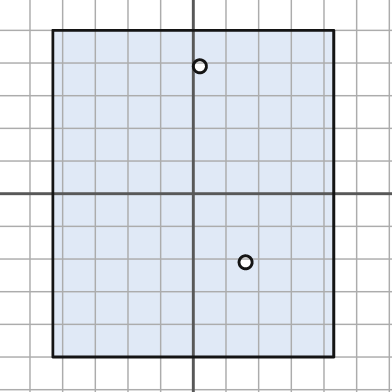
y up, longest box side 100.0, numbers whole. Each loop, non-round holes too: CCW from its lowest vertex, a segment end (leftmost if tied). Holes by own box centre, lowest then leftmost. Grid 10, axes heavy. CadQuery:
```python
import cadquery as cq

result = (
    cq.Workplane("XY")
    .moveTo(-43.0, -50.0)
    .lineTo(43.0, -50.0)
    .lineTo(43.0, 50.0)
    .lineTo(-43.0, 50.0)
    .close()
    .moveTo(16.0, -21.0)
    .circle(2.0)
    .moveTo(2.0, 39.0)
    .circle(2.0)
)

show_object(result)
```